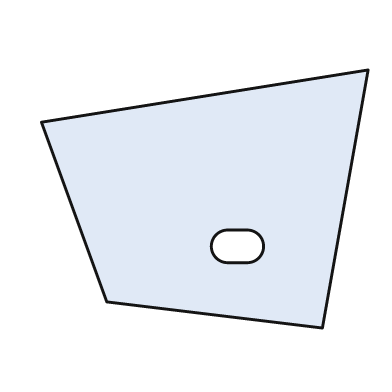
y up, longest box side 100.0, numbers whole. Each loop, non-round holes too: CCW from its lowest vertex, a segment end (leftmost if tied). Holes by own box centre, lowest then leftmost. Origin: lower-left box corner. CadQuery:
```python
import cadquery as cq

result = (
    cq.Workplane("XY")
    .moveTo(86.0, 0.0)
    .lineTo(100.0, 79.0)
    .lineTo(0.0, 63.0)
    .lineTo(20.0, 8.0)
    .close()
    .moveTo(57.0, 20.0)
    .lineTo(63.0, 20.0)
    .threePointArc((68.0, 25.0), (63.0, 30.0))
    .lineTo(57.0, 30.0)
    .threePointArc((52.0, 25.0), (57.0, 20.0))
    .close()
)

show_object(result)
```